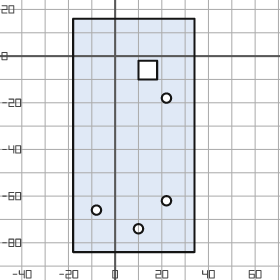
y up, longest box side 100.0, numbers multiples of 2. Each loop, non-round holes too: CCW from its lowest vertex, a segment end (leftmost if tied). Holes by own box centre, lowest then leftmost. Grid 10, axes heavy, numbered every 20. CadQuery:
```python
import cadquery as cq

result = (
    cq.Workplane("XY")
    .moveTo(-18.0, -84.0)
    .lineTo(34.0, -84.0)
    .lineTo(34.0, 16.0)
    .lineTo(-18.0, 16.0)
    .close()
    .moveTo(10.0, -74.0)
    .circle(2.0)
    .moveTo(-8.0, -66.0)
    .circle(2.0)
    .moveTo(22.0, -62.0)
    .circle(2.0)
    .moveTo(22.0, -18.0)
    .circle(2.0)
    .moveTo(10.0, -10.0)
    .lineTo(18.0, -10.0)
    .lineTo(18.0, -2.0)
    .lineTo(10.0, -2.0)
    .close()
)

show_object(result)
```